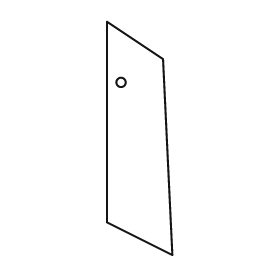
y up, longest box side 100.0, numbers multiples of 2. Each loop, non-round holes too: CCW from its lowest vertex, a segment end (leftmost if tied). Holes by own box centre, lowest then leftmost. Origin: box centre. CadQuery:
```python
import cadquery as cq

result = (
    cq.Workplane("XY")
    .moveTo(14.0, -50.0)
    .lineTo(10.0, 34.0)
    .lineTo(-14.0, 50.0)
    .lineTo(-14.0, -36.0)
    .close()
    .moveTo(-8.0, 24.0)
    .circle(2.0)
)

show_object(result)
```